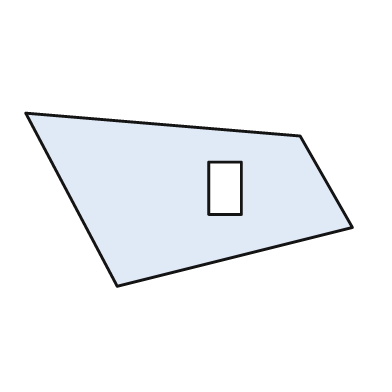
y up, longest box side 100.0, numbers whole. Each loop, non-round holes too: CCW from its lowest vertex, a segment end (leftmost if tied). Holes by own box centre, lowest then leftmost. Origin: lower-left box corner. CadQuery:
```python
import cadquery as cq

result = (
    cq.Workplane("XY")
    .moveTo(28.0, 0.0)
    .lineTo(100.0, 18.0)
    .lineTo(84.0, 46.0)
    .lineTo(0.0, 53.0)
    .close()
    .moveTo(56.0, 22.0)
    .lineTo(66.0, 22.0)
    .lineTo(66.0, 38.0)
    .lineTo(56.0, 38.0)
    .close()
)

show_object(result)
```